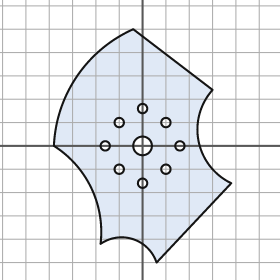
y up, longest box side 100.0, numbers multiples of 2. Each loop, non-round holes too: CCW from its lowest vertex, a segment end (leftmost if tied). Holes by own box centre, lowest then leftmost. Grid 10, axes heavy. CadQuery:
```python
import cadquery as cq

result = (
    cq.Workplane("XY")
    .moveTo(6.0, -50.0)
    .lineTo(38.0, -16.0)
    .threePointArc((24.0, 2.0), (30.0, 24.0))
    .lineTo(-4.0, 50.0)
    .threePointArc((-28.0, 30.0), (-38.0, 0.0))
    .threePointArc((-22.0, -18.0), (-18.0, -42.0))
    .threePointArc((-4.0, -40.0), (6.0, -50.0))
    .close()
    .moveTo(0.0, -16.0)
    .circle(2.0)
    .moveTo(-10.0, -10.0)
    .circle(2.0)
    .moveTo(10.0, -10.0)
    .circle(2.0)
    .moveTo(-16.0, 0.0)
    .circle(2.0)
    .moveTo(0.0, 0.0)
    .circle(4.0)
    .moveTo(16.0, 0.0)
    .circle(2.0)
    .moveTo(-10.0, 10.0)
    .circle(2.0)
    .moveTo(10.0, 10.0)
    .circle(2.0)
    .moveTo(0.0, 16.0)
    .circle(2.0)
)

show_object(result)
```